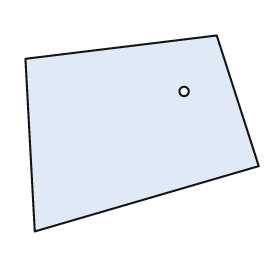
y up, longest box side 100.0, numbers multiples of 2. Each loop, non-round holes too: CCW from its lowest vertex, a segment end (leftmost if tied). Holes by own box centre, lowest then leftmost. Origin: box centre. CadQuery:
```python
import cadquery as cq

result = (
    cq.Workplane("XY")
    .moveTo(-46.0, -42.0)
    .lineTo(50.0, -14.0)
    .lineTo(32.0, 42.0)
    .lineTo(-50.0, 32.0)
    .close()
    .moveTo(18.0, 18.0)
    .circle(2.0)
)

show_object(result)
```